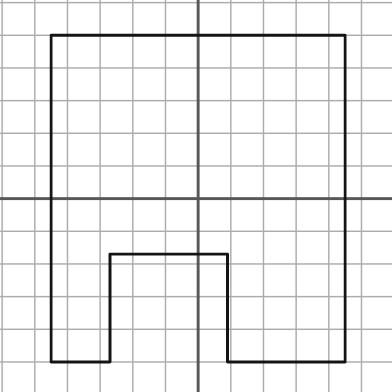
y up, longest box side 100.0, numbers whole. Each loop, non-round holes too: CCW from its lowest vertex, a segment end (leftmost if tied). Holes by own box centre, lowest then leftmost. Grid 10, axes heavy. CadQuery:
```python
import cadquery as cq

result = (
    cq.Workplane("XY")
    .moveTo(-45.0, -50.0)
    .lineTo(-27.0, -50.0)
    .lineTo(-27.0, -17.0)
    .lineTo(9.0, -17.0)
    .lineTo(9.0, -50.0)
    .lineTo(45.0, -50.0)
    .lineTo(45.0, 50.0)
    .lineTo(-45.0, 50.0)
    .close()
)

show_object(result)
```